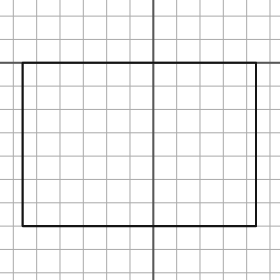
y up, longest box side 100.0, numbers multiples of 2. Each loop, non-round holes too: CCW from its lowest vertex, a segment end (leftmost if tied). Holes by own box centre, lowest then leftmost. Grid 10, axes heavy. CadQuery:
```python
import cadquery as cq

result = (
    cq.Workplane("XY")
    .moveTo(-56.0, -70.0)
    .lineTo(44.0, -70.0)
    .lineTo(44.0, 0.0)
    .lineTo(-56.0, 0.0)
    .close()
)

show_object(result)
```